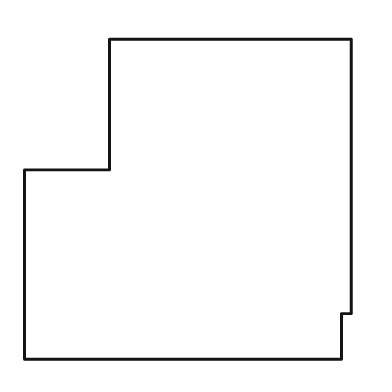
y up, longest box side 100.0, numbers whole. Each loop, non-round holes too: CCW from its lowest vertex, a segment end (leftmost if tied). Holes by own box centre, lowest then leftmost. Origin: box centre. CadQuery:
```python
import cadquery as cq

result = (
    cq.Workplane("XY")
    .moveTo(-50.0, -49.0)
    .lineTo(47.0, -49.0)
    .lineTo(47.0, -35.0)
    .lineTo(50.0, -35.0)
    .lineTo(50.0, 49.0)
    .lineTo(-24.0, 49.0)
    .lineTo(-24.0, 9.0)
    .lineTo(-50.0, 9.0)
    .close()
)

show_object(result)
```